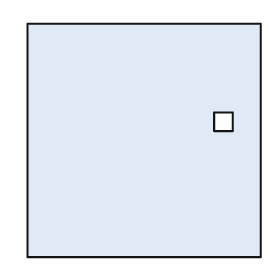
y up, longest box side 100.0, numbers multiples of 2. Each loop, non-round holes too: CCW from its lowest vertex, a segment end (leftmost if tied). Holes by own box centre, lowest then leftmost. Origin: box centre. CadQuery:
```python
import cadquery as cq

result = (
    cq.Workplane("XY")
    .moveTo(-50.0, -50.0)
    .lineTo(50.0, -50.0)
    .lineTo(50.0, 50.0)
    .lineTo(-50.0, 50.0)
    .close()
    .moveTo(30.0, 4.0)
    .lineTo(38.0, 4.0)
    .lineTo(38.0, 12.0)
    .lineTo(30.0, 12.0)
    .close()
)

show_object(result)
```